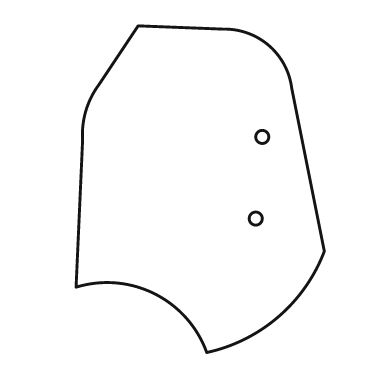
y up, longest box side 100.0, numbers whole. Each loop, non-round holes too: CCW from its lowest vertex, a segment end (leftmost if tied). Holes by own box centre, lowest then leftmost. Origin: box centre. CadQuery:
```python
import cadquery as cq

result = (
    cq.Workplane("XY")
    .moveTo(2.0, -50.0)
    .threePointArc((24.0, -39.0), (38.0, -19.0))
    .lineTo(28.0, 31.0)
    .threePointArc((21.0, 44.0), (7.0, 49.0))
    .lineTo(-19.0, 50.0)
    .lineTo(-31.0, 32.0)
    .threePointArc((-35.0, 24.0), (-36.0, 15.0))
    .lineTo(-38.0, -30.0)
    .threePointArc((-14.0, -32.0), (2.0, -50.0))
    .close()
    .moveTo(17.0, -9.0)
    .circle(2.0)
    .moveTo(19.0, 16.0)
    .circle(2.0)
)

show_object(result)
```